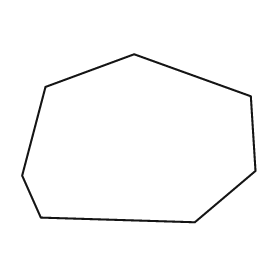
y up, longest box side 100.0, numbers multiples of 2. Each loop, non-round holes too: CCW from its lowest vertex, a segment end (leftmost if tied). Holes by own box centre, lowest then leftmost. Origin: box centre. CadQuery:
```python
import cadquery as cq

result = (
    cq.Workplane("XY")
    .moveTo(24.0, -36.0)
    .lineTo(50.0, -14.0)
    .lineTo(48.0, 18.0)
    .lineTo(-2.0, 36.0)
    .lineTo(-40.0, 22.0)
    .lineTo(-50.0, -16.0)
    .lineTo(-42.0, -34.0)
    .close()
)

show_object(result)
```